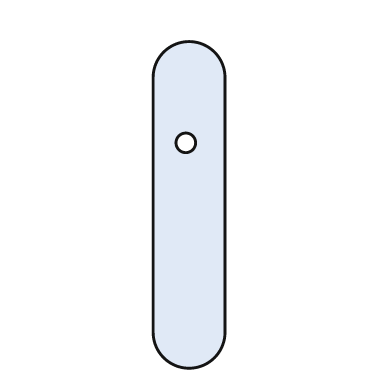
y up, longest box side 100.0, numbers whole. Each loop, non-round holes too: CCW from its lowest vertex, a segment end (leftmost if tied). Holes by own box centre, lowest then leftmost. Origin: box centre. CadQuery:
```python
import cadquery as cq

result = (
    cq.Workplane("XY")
    .moveTo(-11.0, -39.0)
    .threePointArc((0.0, -50.0), (11.0, -39.0))
    .lineTo(11.0, 39.0)
    .threePointArc((0.0, 50.0), (-11.0, 39.0))
    .close()
    .moveTo(-1.0, 19.0)
    .circle(3.0)
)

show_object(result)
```